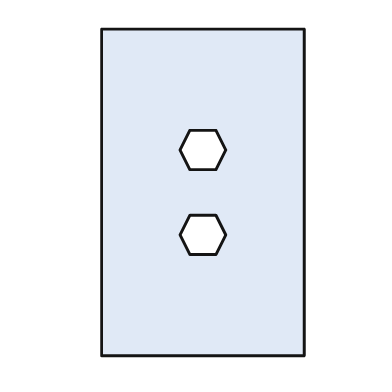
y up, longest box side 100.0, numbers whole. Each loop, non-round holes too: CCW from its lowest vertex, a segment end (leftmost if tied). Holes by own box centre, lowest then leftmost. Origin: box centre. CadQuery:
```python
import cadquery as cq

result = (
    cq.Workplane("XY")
    .moveTo(-31.0, -50.0)
    .lineTo(31.0, -50.0)
    .lineTo(31.0, 50.0)
    .lineTo(-31.0, 50.0)
    .close()
    .moveTo(-4.0, -19.0)
    .lineTo(4.0, -19.0)
    .lineTo(7.0, -13.0)
    .lineTo(4.0, -7.0)
    .lineTo(-4.0, -7.0)
    .lineTo(-7.0, -13.0)
    .close()
    .moveTo(-4.0, 7.0)
    .lineTo(4.0, 7.0)
    .lineTo(7.0, 13.0)
    .lineTo(4.0, 19.0)
    .lineTo(-4.0, 19.0)
    .lineTo(-7.0, 13.0)
    .close()
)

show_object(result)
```